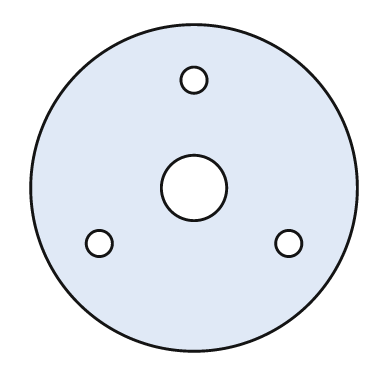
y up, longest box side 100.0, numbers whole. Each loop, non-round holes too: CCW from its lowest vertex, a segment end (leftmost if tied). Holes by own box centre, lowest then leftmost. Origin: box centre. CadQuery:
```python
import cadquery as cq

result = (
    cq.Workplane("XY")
    .moveTo(0.0, 0.0)
    .circle(50.0)
    .moveTo(-29.0, -17.0)
    .circle(4.0)
    .moveTo(29.0, -17.0)
    .circle(4.0)
    .moveTo(0.0, 0.0)
    .circle(10.0)
    .moveTo(0.0, 33.0)
    .circle(4.0)
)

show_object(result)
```